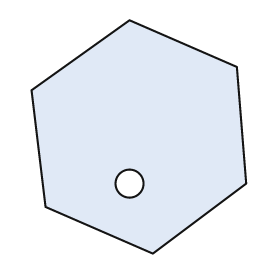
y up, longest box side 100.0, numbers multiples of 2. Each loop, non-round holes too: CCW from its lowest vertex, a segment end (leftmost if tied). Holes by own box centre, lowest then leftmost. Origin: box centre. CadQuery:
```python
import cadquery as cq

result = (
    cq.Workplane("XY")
    .moveTo(6.0, -50.0)
    .lineTo(46.0, -20.0)
    .lineTo(42.0, 30.0)
    .lineTo(-4.0, 50.0)
    .lineTo(-46.0, 20.0)
    .lineTo(-40.0, -30.0)
    .close()
    .moveTo(-4.0, -20.0)
    .circle(6.0)
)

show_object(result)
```